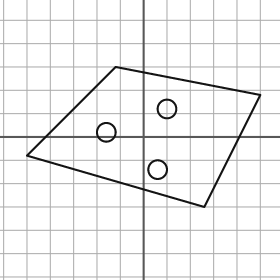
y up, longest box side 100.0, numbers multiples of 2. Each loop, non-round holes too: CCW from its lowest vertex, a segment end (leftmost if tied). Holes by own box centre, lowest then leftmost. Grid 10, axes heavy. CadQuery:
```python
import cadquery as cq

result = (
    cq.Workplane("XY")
    .moveTo(26.0, -30.0)
    .lineTo(50.0, 18.0)
    .lineTo(-12.0, 30.0)
    .lineTo(-50.0, -8.0)
    .close()
    .moveTo(6.0, -14.0)
    .circle(4.0)
    .moveTo(-16.0, 2.0)
    .circle(4.0)
    .moveTo(10.0, 12.0)
    .circle(4.0)
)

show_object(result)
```